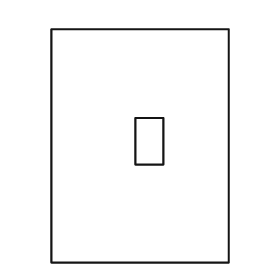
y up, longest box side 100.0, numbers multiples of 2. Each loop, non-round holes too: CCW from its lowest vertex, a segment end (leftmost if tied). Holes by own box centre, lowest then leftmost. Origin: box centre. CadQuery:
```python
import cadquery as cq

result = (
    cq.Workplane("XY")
    .moveTo(-38.0, -50.0)
    .lineTo(38.0, -50.0)
    .lineTo(38.0, 50.0)
    .lineTo(-38.0, 50.0)
    .close()
    .moveTo(-2.0, -8.0)
    .lineTo(10.0, -8.0)
    .lineTo(10.0, 12.0)
    .lineTo(-2.0, 12.0)
    .close()
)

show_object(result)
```